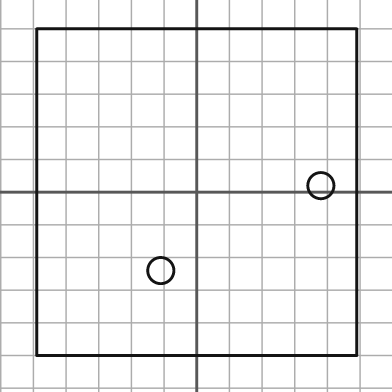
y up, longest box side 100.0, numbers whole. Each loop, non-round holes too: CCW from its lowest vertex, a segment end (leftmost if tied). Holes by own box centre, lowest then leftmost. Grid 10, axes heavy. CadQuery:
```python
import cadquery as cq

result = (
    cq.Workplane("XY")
    .moveTo(-49.0, -50.0)
    .lineTo(49.0, -50.0)
    .lineTo(49.0, 50.0)
    .lineTo(-49.0, 50.0)
    .close()
    .moveTo(-11.0, -24.0)
    .circle(4.0)
    .moveTo(38.0, 2.0)
    .circle(4.0)
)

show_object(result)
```